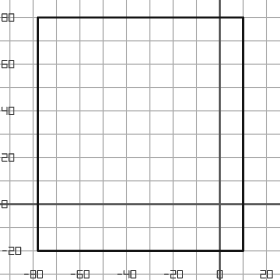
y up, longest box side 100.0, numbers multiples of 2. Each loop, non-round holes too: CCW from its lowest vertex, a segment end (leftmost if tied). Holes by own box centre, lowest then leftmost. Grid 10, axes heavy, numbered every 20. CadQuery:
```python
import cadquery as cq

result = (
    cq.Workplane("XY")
    .moveTo(-78.0, -20.0)
    .lineTo(10.0, -20.0)
    .lineTo(10.0, 80.0)
    .lineTo(-78.0, 80.0)
    .close()
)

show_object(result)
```